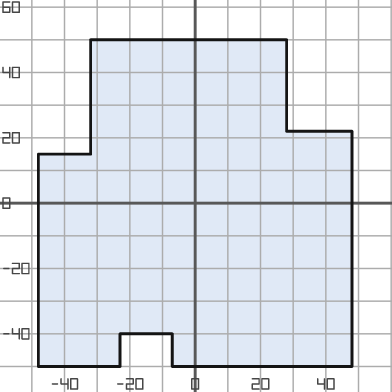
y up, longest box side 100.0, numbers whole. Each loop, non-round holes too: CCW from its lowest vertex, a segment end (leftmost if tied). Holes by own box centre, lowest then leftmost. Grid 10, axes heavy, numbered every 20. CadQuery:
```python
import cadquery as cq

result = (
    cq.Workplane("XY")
    .moveTo(-48.0, -50.0)
    .lineTo(-23.0, -50.0)
    .lineTo(-23.0, -40.0)
    .lineTo(-7.0, -40.0)
    .lineTo(-7.0, -50.0)
    .lineTo(48.0, -50.0)
    .lineTo(48.0, 22.0)
    .lineTo(28.0, 22.0)
    .lineTo(28.0, 50.0)
    .lineTo(-32.0, 50.0)
    .lineTo(-32.0, 15.0)
    .lineTo(-48.0, 15.0)
    .close()
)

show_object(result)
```